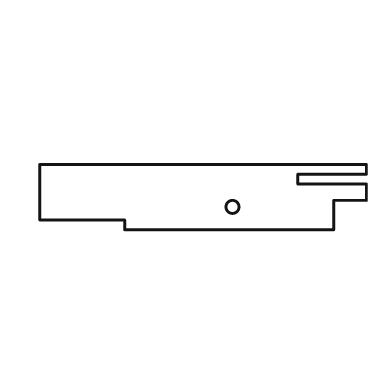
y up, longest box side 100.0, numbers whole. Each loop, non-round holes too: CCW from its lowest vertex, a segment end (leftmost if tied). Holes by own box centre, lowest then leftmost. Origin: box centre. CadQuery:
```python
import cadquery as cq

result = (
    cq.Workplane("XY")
    .moveTo(-24.0, -10.0)
    .lineTo(40.0, -10.0)
    .lineTo(40.0, -1.0)
    .lineTo(50.0, -1.0)
    .lineTo(50.0, 4.0)
    .lineTo(29.0, 4.0)
    .lineTo(29.0, 7.0)
    .lineTo(50.0, 7.0)
    .lineTo(50.0, 10.0)
    .lineTo(-50.0, 10.0)
    .lineTo(-50.0, -7.0)
    .lineTo(-24.0, -7.0)
    .close()
    .moveTo(9.0, -3.0)
    .circle(2.0)
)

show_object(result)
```